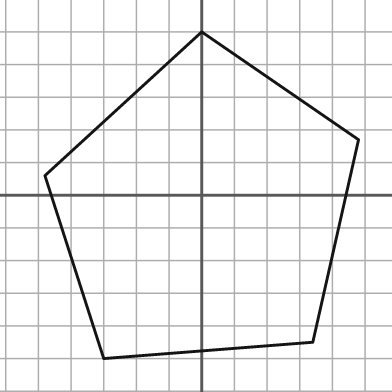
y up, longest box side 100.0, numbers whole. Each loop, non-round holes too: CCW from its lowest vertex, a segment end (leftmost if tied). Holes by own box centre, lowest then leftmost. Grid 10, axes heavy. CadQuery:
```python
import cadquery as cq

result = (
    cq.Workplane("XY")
    .moveTo(-30.0, -50.0)
    .lineTo(34.0, -45.0)
    .lineTo(48.0, 17.0)
    .lineTo(0.0, 50.0)
    .lineTo(-48.0, 6.0)
    .close()
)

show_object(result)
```